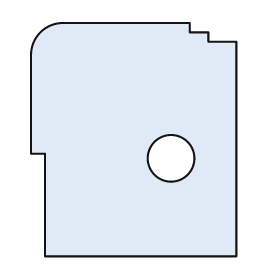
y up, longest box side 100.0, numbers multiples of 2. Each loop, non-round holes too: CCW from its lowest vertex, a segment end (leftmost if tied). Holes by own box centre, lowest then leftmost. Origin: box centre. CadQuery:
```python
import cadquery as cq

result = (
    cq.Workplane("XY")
    .moveTo(-38.0, -50.0)
    .lineTo(44.0, -50.0)
    .lineTo(44.0, 42.0)
    .lineTo(32.0, 42.0)
    .lineTo(32.0, 46.0)
    .lineTo(24.0, 46.0)
    .lineTo(24.0, 50.0)
    .lineTo(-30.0, 50.0)
    .threePointArc((-40.0, 46.0), (-44.0, 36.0))
    .lineTo(-44.0, -6.0)
    .lineTo(-38.0, -6.0)
    .close()
    .moveTo(16.0, -8.0)
    .circle(10.0)
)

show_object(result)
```